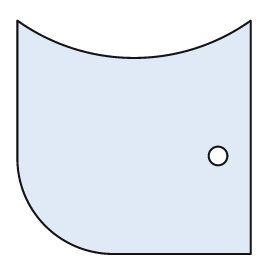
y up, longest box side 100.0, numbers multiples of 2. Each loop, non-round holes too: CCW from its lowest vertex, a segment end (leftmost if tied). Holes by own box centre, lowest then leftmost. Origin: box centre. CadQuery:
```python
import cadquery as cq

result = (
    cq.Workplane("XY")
    .moveTo(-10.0, -50.0)
    .lineTo(50.0, -50.0)
    .lineTo(50.0, 50.0)
    .threePointArc((0.0, 34.0), (-50.0, 50.0))
    .lineTo(-50.0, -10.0)
    .threePointArc((-38.0, -38.0), (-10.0, -50.0))
    .close()
    .moveTo(36.0, -8.0)
    .circle(4.0)
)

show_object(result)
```